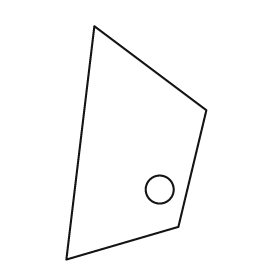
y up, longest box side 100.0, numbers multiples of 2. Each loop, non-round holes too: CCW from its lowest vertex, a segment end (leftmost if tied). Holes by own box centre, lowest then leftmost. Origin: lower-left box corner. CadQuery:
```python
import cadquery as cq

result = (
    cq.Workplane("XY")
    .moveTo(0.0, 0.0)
    .lineTo(48.0, 14.0)
    .lineTo(60.0, 64.0)
    .lineTo(12.0, 100.0)
    .close()
    .moveTo(40.0, 30.0)
    .circle(6.0)
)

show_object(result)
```